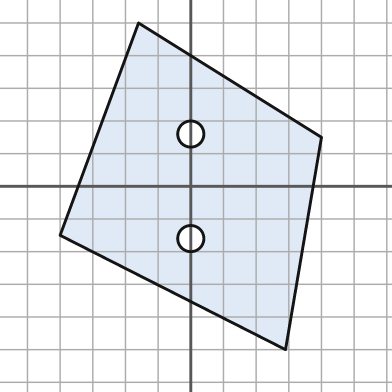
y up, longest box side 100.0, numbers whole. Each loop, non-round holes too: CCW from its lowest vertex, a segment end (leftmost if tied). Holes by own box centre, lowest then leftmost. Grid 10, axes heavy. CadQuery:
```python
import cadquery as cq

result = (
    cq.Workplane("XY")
    .moveTo(29.0, -50.0)
    .lineTo(40.0, 15.0)
    .lineTo(-16.0, 50.0)
    .lineTo(-40.0, -15.0)
    .close()
    .moveTo(0.0, -16.0)
    .circle(4.0)
    .moveTo(0.0, 16.0)
    .circle(4.0)
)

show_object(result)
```